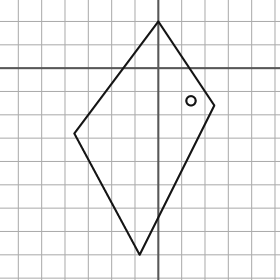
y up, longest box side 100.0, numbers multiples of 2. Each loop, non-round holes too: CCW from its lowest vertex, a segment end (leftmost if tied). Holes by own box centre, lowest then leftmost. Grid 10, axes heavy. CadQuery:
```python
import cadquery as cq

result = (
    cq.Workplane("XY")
    .moveTo(-8.0, -80.0)
    .lineTo(24.0, -16.0)
    .lineTo(0.0, 20.0)
    .lineTo(-36.0, -28.0)
    .close()
    .moveTo(14.0, -14.0)
    .circle(2.0)
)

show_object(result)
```